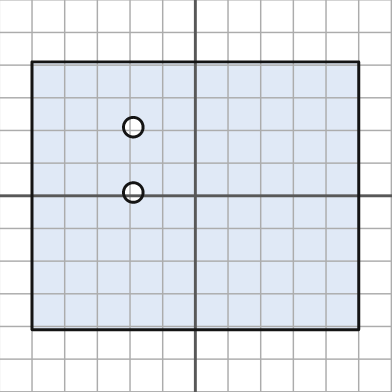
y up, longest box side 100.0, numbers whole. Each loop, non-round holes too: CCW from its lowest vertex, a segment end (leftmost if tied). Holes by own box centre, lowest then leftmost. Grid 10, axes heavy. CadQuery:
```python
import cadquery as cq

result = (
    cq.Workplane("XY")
    .moveTo(-50.0, -41.0)
    .lineTo(50.0, -41.0)
    .lineTo(50.0, 41.0)
    .lineTo(-50.0, 41.0)
    .close()
    .moveTo(-19.0, 1.0)
    .circle(3.0)
    .moveTo(-19.0, 21.0)
    .circle(3.0)
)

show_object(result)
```